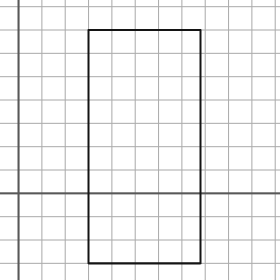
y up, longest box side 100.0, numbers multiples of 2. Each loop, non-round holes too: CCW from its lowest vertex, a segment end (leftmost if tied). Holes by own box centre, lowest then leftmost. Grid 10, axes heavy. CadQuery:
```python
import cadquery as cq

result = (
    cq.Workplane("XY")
    .moveTo(30.0, -30.0)
    .lineTo(78.0, -30.0)
    .lineTo(78.0, 70.0)
    .lineTo(30.0, 70.0)
    .close()
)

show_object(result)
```